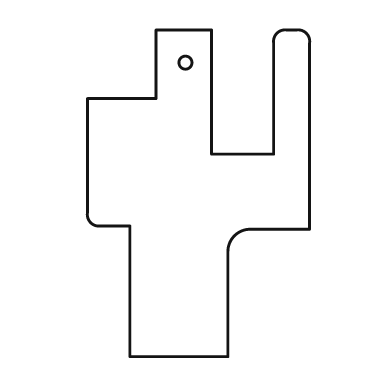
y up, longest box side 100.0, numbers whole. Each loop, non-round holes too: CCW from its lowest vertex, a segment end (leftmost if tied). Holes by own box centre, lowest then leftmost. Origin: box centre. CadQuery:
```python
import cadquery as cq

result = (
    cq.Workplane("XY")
    .moveTo(-21.0, -50.0)
    .lineTo(9.0, -50.0)
    .lineTo(9.0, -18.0)
    .threePointArc((11.0, -13.0), (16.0, -11.0))
    .lineTo(34.0, -11.0)
    .lineTo(34.0, 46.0)
    .threePointArc((33.0, 49.0), (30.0, 50.0))
    .lineTo(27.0, 50.0)
    .threePointArc((24.0, 49.0), (23.0, 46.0))
    .lineTo(23.0, 12.0)
    .lineTo(4.0, 12.0)
    .lineTo(4.0, 50.0)
    .lineTo(-13.0, 50.0)
    .lineTo(-13.0, 29.0)
    .lineTo(-34.0, 29.0)
    .lineTo(-34.0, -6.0)
    .threePointArc((-33.0, -9.0), (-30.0, -10.0))
    .lineTo(-21.0, -10.0)
    .close()
    .moveTo(-4.0, 40.0)
    .circle(2.0)
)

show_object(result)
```